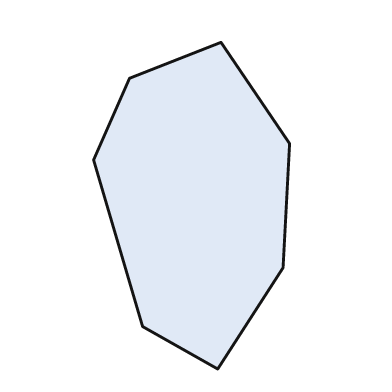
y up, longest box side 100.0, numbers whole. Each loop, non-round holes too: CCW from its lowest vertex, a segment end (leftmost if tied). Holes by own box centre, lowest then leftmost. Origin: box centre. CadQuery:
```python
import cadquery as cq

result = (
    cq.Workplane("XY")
    .moveTo(8.0, -50.0)
    .lineTo(28.0, -19.0)
    .lineTo(30.0, 19.0)
    .lineTo(9.0, 50.0)
    .lineTo(-19.0, 39.0)
    .lineTo(-30.0, 14.0)
    .lineTo(-15.0, -37.0)
    .close()
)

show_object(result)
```